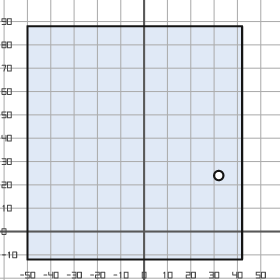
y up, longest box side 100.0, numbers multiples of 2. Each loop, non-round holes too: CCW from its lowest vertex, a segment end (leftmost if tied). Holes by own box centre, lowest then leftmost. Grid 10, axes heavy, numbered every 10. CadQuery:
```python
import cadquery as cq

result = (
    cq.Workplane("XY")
    .moveTo(-50.0, -12.0)
    .lineTo(42.0, -12.0)
    .lineTo(42.0, 88.0)
    .lineTo(-50.0, 88.0)
    .close()
    .moveTo(32.0, 24.0)
    .circle(2.0)
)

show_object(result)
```